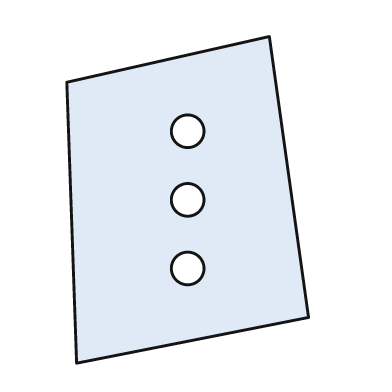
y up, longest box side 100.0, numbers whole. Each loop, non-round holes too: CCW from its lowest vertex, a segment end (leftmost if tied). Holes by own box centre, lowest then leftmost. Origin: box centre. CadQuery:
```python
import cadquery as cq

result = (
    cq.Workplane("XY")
    .moveTo(-34.0, -50.0)
    .lineTo(37.0, -36.0)
    .lineTo(25.0, 50.0)
    .lineTo(-37.0, 36.0)
    .close()
    .moveTo(0.0, -21.0)
    .circle(5.0)
    .moveTo(0.0, 0.0)
    .circle(5.0)
    .moveTo(0.0, 21.0)
    .circle(5.0)
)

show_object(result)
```